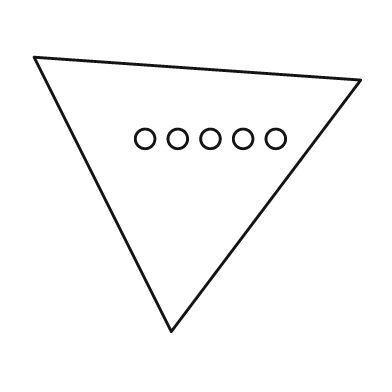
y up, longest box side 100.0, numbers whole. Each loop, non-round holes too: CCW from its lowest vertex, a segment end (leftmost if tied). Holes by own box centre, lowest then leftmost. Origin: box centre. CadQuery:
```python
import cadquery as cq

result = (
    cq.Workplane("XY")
    .moveTo(-8.0, -42.0)
    .lineTo(50.0, 35.0)
    .lineTo(-50.0, 42.0)
    .close()
    .moveTo(-16.0, 17.0)
    .circle(3.0)
    .moveTo(-6.0, 17.0)
    .circle(3.0)
    .moveTo(4.0, 17.0)
    .circle(3.0)
    .moveTo(14.0, 17.0)
    .circle(3.0)
    .moveTo(24.0, 17.0)
    .circle(3.0)
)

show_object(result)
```